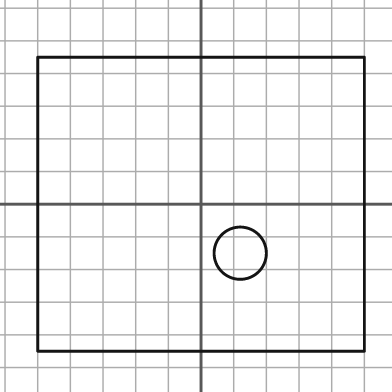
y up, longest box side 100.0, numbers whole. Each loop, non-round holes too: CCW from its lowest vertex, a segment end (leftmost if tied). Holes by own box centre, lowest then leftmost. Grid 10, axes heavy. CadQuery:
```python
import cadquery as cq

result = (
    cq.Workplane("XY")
    .moveTo(-50.0, -45.0)
    .lineTo(50.0, -45.0)
    .lineTo(50.0, 45.0)
    .lineTo(-50.0, 45.0)
    .close()
    .moveTo(12.0, -15.0)
    .circle(8.0)
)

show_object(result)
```